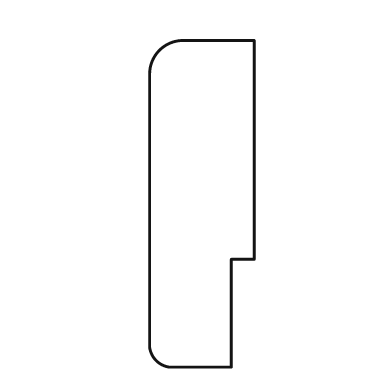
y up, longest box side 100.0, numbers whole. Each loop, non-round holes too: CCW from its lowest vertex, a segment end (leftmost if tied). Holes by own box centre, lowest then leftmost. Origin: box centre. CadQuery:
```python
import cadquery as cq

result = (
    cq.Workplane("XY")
    .moveTo(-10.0, -50.0)
    .lineTo(9.0, -50.0)
    .lineTo(9.0, -17.0)
    .lineTo(16.0, -17.0)
    .lineTo(16.0, 50.0)
    .lineTo(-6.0, 50.0)
    .threePointArc((-13.0, 47.0), (-16.0, 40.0))
    .lineTo(-16.0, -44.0)
    .threePointArc((-14.0, -48.0), (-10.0, -50.0))
    .close()
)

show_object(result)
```